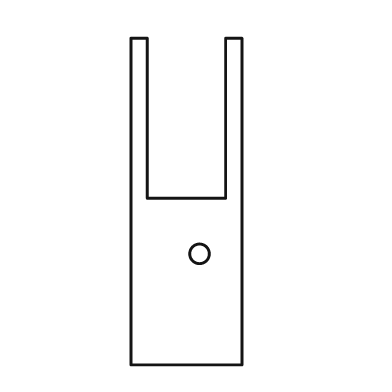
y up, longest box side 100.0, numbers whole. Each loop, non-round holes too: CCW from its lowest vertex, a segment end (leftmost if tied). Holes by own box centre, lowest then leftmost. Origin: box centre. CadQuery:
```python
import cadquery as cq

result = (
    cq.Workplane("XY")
    .moveTo(-17.0, -50.0)
    .lineTo(17.0, -50.0)
    .lineTo(17.0, 50.0)
    .lineTo(12.0, 50.0)
    .lineTo(12.0, 1.0)
    .lineTo(-12.0, 1.0)
    .lineTo(-12.0, 50.0)
    .lineTo(-17.0, 50.0)
    .close()
    .moveTo(4.0, -16.0)
    .circle(3.0)
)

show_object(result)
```